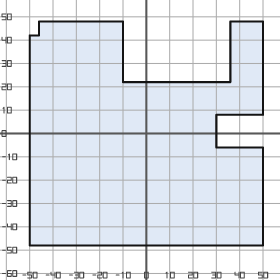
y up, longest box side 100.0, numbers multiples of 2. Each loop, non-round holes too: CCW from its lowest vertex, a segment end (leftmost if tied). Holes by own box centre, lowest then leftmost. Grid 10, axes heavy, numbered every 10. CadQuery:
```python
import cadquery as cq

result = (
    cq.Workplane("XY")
    .moveTo(-50.0, -48.0)
    .lineTo(50.0, -48.0)
    .lineTo(50.0, -6.0)
    .lineTo(30.0, -6.0)
    .lineTo(30.0, 8.0)
    .lineTo(50.0, 8.0)
    .lineTo(50.0, 48.0)
    .lineTo(36.0, 48.0)
    .lineTo(36.0, 22.0)
    .lineTo(-10.0, 22.0)
    .lineTo(-10.0, 48.0)
    .lineTo(-46.0, 48.0)
    .lineTo(-46.0, 42.0)
    .lineTo(-50.0, 42.0)
    .close()
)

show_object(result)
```